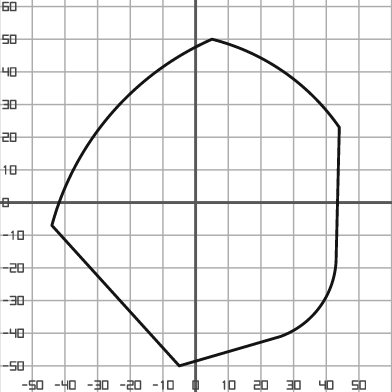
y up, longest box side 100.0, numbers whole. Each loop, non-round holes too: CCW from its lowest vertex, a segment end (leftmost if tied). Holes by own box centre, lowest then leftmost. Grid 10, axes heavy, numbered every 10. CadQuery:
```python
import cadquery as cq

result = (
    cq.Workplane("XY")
    .moveTo(-5.0, -50.0)
    .lineTo(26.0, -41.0)
    .threePointArc((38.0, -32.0), (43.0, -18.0))
    .lineTo(44.0, 23.0)
    .threePointArc((27.0, 40.0), (5.0, 50.0))
    .threePointArc((-26.0, 27.0), (-44.0, -7.0))
    .close()
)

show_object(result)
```